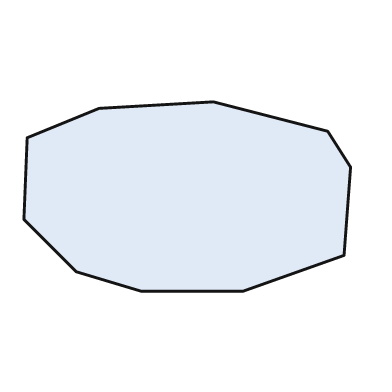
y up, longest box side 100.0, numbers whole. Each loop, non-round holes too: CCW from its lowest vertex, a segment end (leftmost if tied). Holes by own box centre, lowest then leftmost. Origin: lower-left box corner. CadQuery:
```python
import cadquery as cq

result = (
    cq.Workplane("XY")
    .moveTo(36.0, 0.0)
    .lineTo(67.0, 0.0)
    .lineTo(98.0, 11.0)
    .lineTo(100.0, 38.0)
    .lineTo(93.0, 49.0)
    .lineTo(58.0, 58.0)
    .lineTo(23.0, 56.0)
    .lineTo(1.0, 47.0)
    .lineTo(0.0, 22.0)
    .lineTo(16.0, 6.0)
    .close()
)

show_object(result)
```